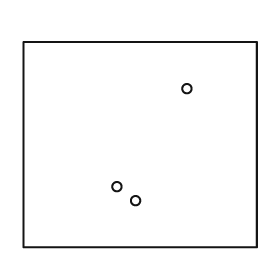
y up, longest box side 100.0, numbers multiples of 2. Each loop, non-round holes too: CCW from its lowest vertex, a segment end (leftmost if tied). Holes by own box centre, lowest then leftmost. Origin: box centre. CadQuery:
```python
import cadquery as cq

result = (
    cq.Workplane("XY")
    .moveTo(-50.0, -44.0)
    .lineTo(50.0, -44.0)
    .lineTo(50.0, 44.0)
    .lineTo(-50.0, 44.0)
    .close()
    .moveTo(-2.0, -24.0)
    .circle(2.0)
    .moveTo(-10.0, -18.0)
    .circle(2.0)
    .moveTo(20.0, 24.0)
    .circle(2.0)
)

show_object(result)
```